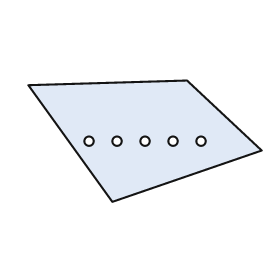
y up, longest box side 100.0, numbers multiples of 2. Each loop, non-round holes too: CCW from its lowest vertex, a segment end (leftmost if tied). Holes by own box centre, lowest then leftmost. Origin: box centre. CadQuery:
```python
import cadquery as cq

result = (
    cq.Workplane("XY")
    .moveTo(-14.0, -26.0)
    .lineTo(50.0, -4.0)
    .lineTo(18.0, 26.0)
    .lineTo(-50.0, 24.0)
    .close()
    .moveTo(-24.0, 0.0)
    .circle(2.0)
    .moveTo(-12.0, 0.0)
    .circle(2.0)
    .moveTo(0.0, 0.0)
    .circle(2.0)
    .moveTo(12.0, 0.0)
    .circle(2.0)
    .moveTo(24.0, 0.0)
    .circle(2.0)
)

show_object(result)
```